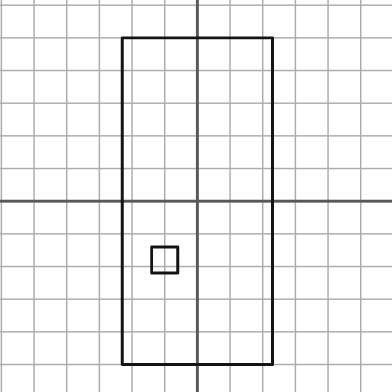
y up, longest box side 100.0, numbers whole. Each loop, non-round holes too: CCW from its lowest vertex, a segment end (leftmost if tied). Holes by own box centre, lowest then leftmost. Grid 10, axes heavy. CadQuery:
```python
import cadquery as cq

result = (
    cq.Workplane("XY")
    .moveTo(-23.0, -50.0)
    .lineTo(23.0, -50.0)
    .lineTo(23.0, 50.0)
    .lineTo(-23.0, 50.0)
    .close()
    .moveTo(-14.0, -22.0)
    .lineTo(-6.0, -22.0)
    .lineTo(-6.0, -14.0)
    .lineTo(-14.0, -14.0)
    .close()
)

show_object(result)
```